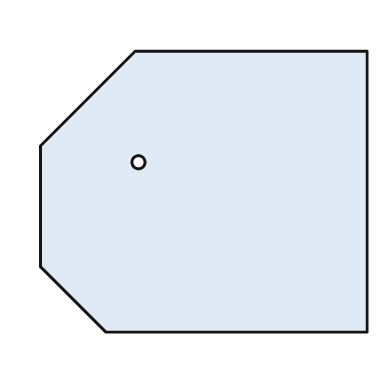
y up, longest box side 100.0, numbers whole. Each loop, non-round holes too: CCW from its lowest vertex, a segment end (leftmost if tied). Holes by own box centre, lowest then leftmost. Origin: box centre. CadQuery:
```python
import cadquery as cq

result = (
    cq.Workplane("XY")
    .moveTo(-30.0, -43.0)
    .lineTo(50.0, -43.0)
    .lineTo(50.0, 43.0)
    .lineTo(-21.0, 43.0)
    .lineTo(-50.0, 14.0)
    .lineTo(-50.0, -23.0)
    .close()
    .moveTo(-20.0, 9.0)
    .circle(2.0)
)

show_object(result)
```